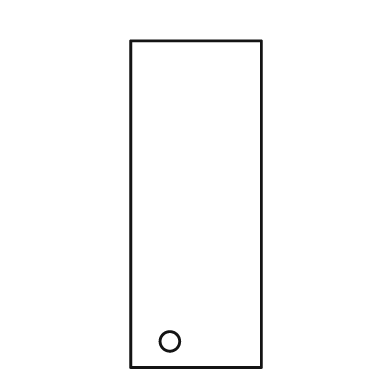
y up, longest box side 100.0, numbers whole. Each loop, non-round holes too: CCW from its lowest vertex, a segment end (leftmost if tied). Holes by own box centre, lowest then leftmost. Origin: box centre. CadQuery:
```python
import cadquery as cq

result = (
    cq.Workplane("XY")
    .moveTo(-20.0, -50.0)
    .lineTo(20.0, -50.0)
    .lineTo(20.0, 50.0)
    .lineTo(-20.0, 50.0)
    .close()
    .moveTo(-8.0, -42.0)
    .circle(3.0)
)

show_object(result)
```